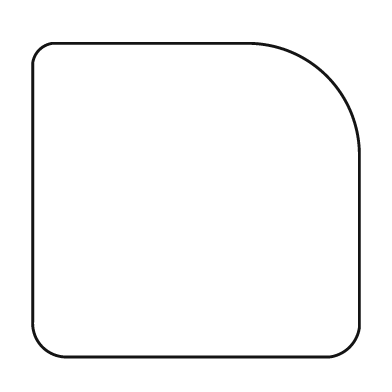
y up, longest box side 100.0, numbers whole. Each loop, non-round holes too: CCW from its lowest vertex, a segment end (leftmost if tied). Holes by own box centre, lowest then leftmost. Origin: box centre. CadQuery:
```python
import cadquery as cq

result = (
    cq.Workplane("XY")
    .moveTo(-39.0, -48.0)
    .lineTo(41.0, -48.0)
    .threePointArc((47.0, -45.0), (50.0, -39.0))
    .lineTo(50.0, 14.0)
    .threePointArc((40.0, 38.0), (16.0, 48.0))
    .lineTo(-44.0, 48.0)
    .threePointArc((-48.0, 46.0), (-50.0, 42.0))
    .lineTo(-50.0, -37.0)
    .threePointArc((-47.0, -45.0), (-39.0, -48.0))
    .close()
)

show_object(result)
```